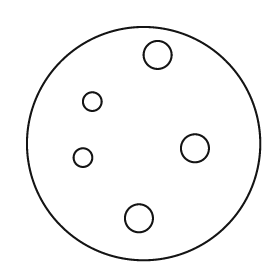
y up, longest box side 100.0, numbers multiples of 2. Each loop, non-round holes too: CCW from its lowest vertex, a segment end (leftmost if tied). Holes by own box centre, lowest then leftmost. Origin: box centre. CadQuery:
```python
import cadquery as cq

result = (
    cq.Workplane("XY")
    .moveTo(0.0, 0.0)
    .circle(50.0)
    .moveTo(-2.0, -32.0)
    .circle(6.0)
    .moveTo(-26.0, -6.0)
    .circle(4.0)
    .moveTo(22.0, -2.0)
    .circle(6.0)
    .moveTo(-22.0, 18.0)
    .circle(4.0)
    .moveTo(6.0, 38.0)
    .circle(6.0)
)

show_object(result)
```